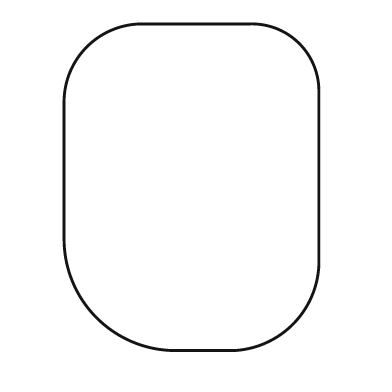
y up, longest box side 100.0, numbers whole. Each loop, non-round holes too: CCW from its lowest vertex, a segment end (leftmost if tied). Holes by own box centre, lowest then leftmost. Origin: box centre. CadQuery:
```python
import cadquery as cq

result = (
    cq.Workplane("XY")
    .moveTo(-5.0, -50.0)
    .lineTo(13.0, -50.0)
    .threePointArc((31.0, -42.0), (39.0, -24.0))
    .lineTo(39.0, 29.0)
    .threePointArc((33.0, 44.0), (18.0, 50.0))
    .lineTo(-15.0, 50.0)
    .threePointArc((-32.0, 43.0), (-39.0, 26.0))
    .lineTo(-39.0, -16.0)
    .threePointArc((-29.0, -40.0), (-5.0, -50.0))
    .close()
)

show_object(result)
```